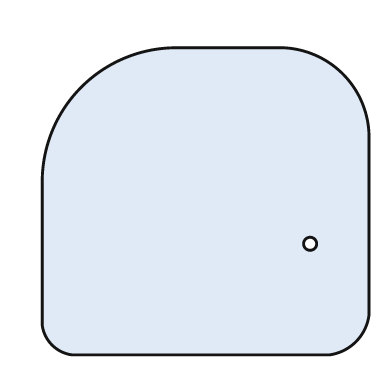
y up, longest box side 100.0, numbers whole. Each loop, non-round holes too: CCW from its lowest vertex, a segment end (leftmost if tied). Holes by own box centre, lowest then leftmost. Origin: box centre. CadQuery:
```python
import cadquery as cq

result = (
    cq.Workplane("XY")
    .moveTo(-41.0, -47.0)
    .lineTo(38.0, -47.0)
    .threePointArc((46.0, -43.0), (50.0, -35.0))
    .lineTo(50.0, 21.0)
    .threePointArc((42.0, 39.0), (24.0, 47.0))
    .lineTo(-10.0, 47.0)
    .threePointArc((-38.0, 35.0), (-50.0, 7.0))
    .lineTo(-50.0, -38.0)
    .threePointArc((-47.0, -44.0), (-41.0, -47.0))
    .close()
    .moveTo(32.0, -13.0)
    .circle(2.0)
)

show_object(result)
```